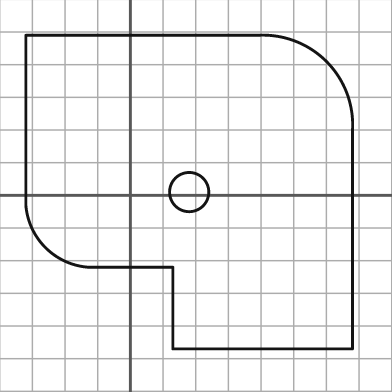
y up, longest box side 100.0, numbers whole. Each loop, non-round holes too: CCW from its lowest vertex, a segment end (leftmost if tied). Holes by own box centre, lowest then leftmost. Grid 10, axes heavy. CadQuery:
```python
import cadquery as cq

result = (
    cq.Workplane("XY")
    .moveTo(13.0, -47.0)
    .lineTo(68.0, -47.0)
    .lineTo(68.0, 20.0)
    .threePointArc((60.0, 41.0), (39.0, 49.0))
    .lineTo(-32.0, 49.0)
    .lineTo(-32.0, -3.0)
    .threePointArc((-26.0, -16.0), (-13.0, -22.0))
    .lineTo(13.0, -22.0)
    .close()
    .moveTo(18.0, 1.0)
    .circle(6.0)
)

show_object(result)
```